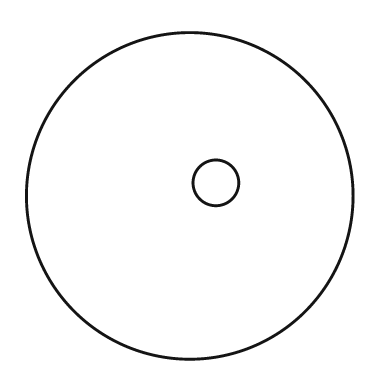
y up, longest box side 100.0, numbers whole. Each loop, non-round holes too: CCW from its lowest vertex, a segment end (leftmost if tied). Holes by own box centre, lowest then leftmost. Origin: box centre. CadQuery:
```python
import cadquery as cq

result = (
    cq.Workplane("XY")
    .moveTo(0.0, 0.0)
    .circle(50.0)
    .moveTo(8.0, 4.0)
    .circle(7.0)
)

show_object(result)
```